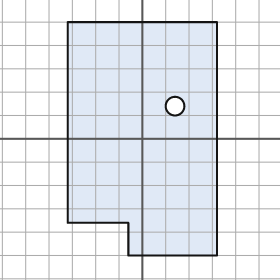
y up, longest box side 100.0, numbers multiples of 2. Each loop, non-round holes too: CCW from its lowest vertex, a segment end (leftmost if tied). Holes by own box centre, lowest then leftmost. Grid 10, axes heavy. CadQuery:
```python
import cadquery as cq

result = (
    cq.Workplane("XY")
    .moveTo(-6.0, -50.0)
    .lineTo(32.0, -50.0)
    .lineTo(32.0, 50.0)
    .lineTo(-32.0, 50.0)
    .lineTo(-32.0, -36.0)
    .lineTo(-6.0, -36.0)
    .close()
    .moveTo(14.0, 14.0)
    .circle(4.0)
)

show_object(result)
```